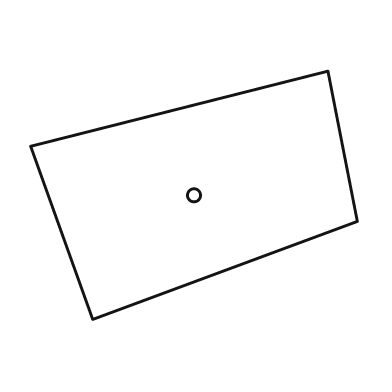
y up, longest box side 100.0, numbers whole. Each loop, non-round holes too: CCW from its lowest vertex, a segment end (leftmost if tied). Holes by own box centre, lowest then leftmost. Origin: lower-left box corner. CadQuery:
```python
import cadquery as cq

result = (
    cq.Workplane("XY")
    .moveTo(19.0, 0.0)
    .lineTo(100.0, 30.0)
    .lineTo(91.0, 76.0)
    .lineTo(0.0, 53.0)
    .close()
    .moveTo(50.0, 38.0)
    .circle(2.0)
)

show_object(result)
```